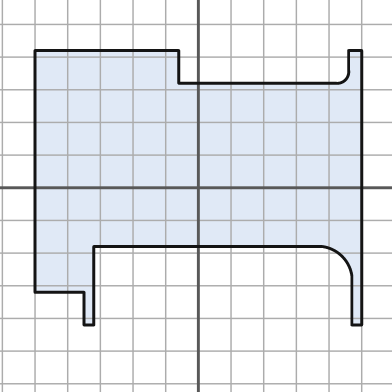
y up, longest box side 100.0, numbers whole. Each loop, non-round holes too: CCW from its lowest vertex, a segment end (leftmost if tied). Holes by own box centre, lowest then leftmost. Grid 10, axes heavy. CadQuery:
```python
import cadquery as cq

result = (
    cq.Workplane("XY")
    .moveTo(-35.0, -42.0)
    .lineTo(-32.0, -42.0)
    .lineTo(-32.0, -18.0)
    .lineTo(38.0, -18.0)
    .threePointArc((44.0, -21.0), (47.0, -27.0))
    .lineTo(47.0, -42.0)
    .lineTo(50.0, -42.0)
    .lineTo(50.0, 42.0)
    .lineTo(46.0, 42.0)
    .lineTo(46.0, 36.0)
    .threePointArc((45.0, 33.0), (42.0, 32.0))
    .lineTo(-6.0, 32.0)
    .lineTo(-6.0, 42.0)
    .lineTo(-50.0, 42.0)
    .lineTo(-50.0, -32.0)
    .lineTo(-35.0, -32.0)
    .close()
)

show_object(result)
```